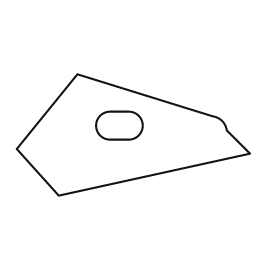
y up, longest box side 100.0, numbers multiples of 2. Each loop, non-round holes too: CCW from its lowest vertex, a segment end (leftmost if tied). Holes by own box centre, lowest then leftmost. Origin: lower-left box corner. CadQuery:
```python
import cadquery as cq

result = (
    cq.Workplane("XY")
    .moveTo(18.0, 0.0)
    .lineTo(100.0, 18.0)
    .lineTo(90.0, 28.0)
    .threePointArc((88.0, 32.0), (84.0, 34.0))
    .lineTo(26.0, 52.0)
    .lineTo(0.0, 20.0)
    .close()
    .moveTo(40.0, 24.0)
    .lineTo(48.0, 24.0)
    .threePointArc((54.0, 30.0), (48.0, 36.0))
    .lineTo(40.0, 36.0)
    .threePointArc((34.0, 30.0), (40.0, 24.0))
    .close()
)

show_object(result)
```